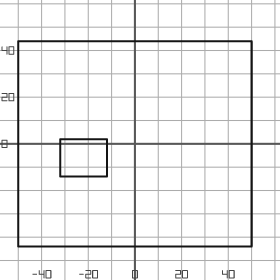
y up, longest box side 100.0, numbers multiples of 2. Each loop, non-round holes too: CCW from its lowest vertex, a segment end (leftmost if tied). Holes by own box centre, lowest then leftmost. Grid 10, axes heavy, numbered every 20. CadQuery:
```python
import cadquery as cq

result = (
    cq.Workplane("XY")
    .moveTo(-50.0, -44.0)
    .lineTo(50.0, -44.0)
    .lineTo(50.0, 44.0)
    .lineTo(-50.0, 44.0)
    .close()
    .moveTo(-32.0, -14.0)
    .lineTo(-12.0, -14.0)
    .lineTo(-12.0, 2.0)
    .lineTo(-32.0, 2.0)
    .close()
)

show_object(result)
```